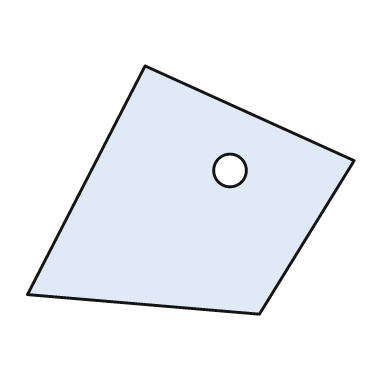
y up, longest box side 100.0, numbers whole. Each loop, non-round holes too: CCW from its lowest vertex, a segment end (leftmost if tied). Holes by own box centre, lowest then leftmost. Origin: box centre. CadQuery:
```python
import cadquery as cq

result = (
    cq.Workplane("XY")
    .moveTo(21.0, -38.0)
    .lineTo(50.0, 9.0)
    .lineTo(-14.0, 38.0)
    .lineTo(-50.0, -32.0)
    .close()
    .moveTo(12.0, 6.0)
    .circle(5.0)
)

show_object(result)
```